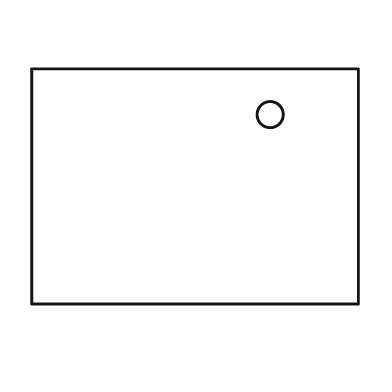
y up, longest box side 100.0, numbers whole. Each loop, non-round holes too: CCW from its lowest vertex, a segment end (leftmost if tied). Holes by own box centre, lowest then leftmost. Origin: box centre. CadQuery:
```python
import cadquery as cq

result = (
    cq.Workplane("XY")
    .moveTo(-50.0, -36.0)
    .lineTo(50.0, -36.0)
    .lineTo(50.0, 36.0)
    .lineTo(-50.0, 36.0)
    .close()
    .moveTo(23.0, 22.0)
    .circle(4.0)
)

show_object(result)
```